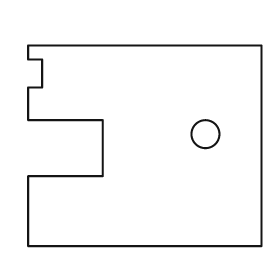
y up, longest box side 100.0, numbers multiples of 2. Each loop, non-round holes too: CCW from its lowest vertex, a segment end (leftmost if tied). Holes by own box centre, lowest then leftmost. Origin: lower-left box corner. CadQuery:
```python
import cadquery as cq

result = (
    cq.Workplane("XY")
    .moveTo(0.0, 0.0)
    .lineTo(100.0, 0.0)
    .lineTo(100.0, 86.0)
    .lineTo(0.0, 86.0)
    .lineTo(0.0, 80.0)
    .lineTo(6.0, 80.0)
    .lineTo(6.0, 68.0)
    .lineTo(0.0, 68.0)
    .lineTo(0.0, 54.0)
    .lineTo(32.0, 54.0)
    .lineTo(32.0, 30.0)
    .lineTo(0.0, 30.0)
    .close()
    .moveTo(76.0, 48.0)
    .circle(6.0)
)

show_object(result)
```